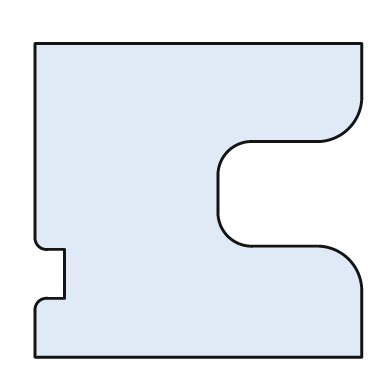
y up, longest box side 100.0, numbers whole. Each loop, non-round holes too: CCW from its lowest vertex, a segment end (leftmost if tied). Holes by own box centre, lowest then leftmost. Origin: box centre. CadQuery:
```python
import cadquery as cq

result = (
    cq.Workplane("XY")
    .moveTo(-50.0, -48.0)
    .lineTo(50.0, -48.0)
    .lineTo(50.0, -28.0)
    .threePointArc((46.0, -18.0), (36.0, -14.0))
    .lineTo(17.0, -14.0)
    .threePointArc((9.0, -11.0), (6.0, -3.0))
    .lineTo(6.0, 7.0)
    .threePointArc((9.0, 15.0), (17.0, 18.0))
    .lineTo(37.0, 18.0)
    .threePointArc((46.0, 22.0), (50.0, 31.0))
    .lineTo(50.0, 48.0)
    .lineTo(-50.0, 48.0)
    .lineTo(-50.0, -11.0)
    .threePointArc((-49.0, -14.0), (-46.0, -15.0))
    .lineTo(-41.0, -15.0)
    .lineTo(-41.0, -30.0)
    .lineTo(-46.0, -30.0)
    .threePointArc((-49.0, -31.0), (-50.0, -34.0))
    .close()
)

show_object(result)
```